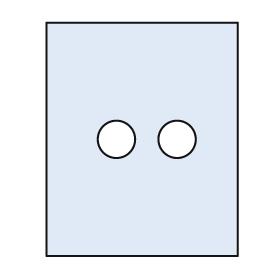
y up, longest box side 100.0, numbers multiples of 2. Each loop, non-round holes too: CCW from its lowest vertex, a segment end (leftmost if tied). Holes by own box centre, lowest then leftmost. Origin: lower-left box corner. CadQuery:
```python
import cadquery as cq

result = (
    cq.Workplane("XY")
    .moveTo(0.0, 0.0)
    .lineTo(82.0, 0.0)
    .lineTo(82.0, 100.0)
    .lineTo(0.0, 100.0)
    .close()
    .moveTo(30.0, 50.0)
    .circle(8.0)
    .moveTo(56.0, 50.0)
    .circle(8.0)
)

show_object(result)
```